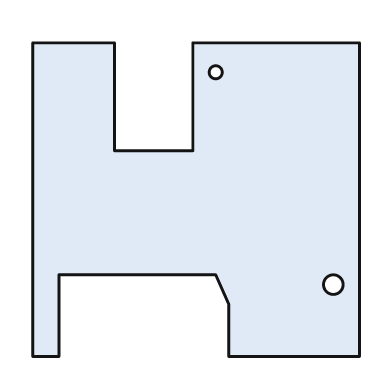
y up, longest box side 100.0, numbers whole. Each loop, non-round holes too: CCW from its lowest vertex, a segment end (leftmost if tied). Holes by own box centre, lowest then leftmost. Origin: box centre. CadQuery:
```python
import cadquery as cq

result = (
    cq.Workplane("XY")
    .moveTo(-50.0, -48.0)
    .lineTo(-42.0, -48.0)
    .lineTo(-42.0, -23.0)
    .lineTo(6.0, -23.0)
    .lineTo(10.0, -32.0)
    .lineTo(10.0, -48.0)
    .lineTo(50.0, -48.0)
    .lineTo(50.0, 48.0)
    .lineTo(-1.0, 48.0)
    .lineTo(-1.0, 15.0)
    .lineTo(-25.0, 15.0)
    .lineTo(-25.0, 48.0)
    .lineTo(-50.0, 48.0)
    .close()
    .moveTo(42.0, -26.0)
    .circle(3.0)
    .moveTo(6.0, 39.0)
    .circle(2.0)
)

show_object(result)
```